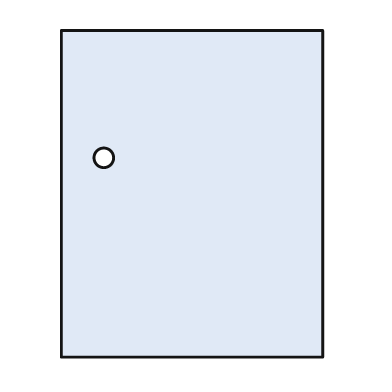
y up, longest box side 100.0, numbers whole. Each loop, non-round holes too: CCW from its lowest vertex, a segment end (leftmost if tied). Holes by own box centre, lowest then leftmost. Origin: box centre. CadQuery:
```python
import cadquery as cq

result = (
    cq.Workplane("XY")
    .moveTo(-40.0, -50.0)
    .lineTo(40.0, -50.0)
    .lineTo(40.0, 50.0)
    .lineTo(-40.0, 50.0)
    .close()
    .moveTo(-27.0, 11.0)
    .circle(3.0)
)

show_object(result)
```